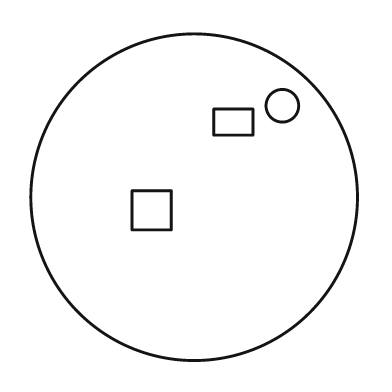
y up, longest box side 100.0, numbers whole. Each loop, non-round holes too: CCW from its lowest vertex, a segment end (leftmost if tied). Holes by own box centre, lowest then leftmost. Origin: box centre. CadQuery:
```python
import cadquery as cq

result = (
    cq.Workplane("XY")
    .moveTo(0.0, 0.0)
    .circle(50.0)
    .moveTo(-19.0, -10.0)
    .lineTo(-7.0, -10.0)
    .lineTo(-7.0, 2.0)
    .lineTo(-19.0, 2.0)
    .close()
    .moveTo(6.0, 19.0)
    .lineTo(18.0, 19.0)
    .lineTo(18.0, 27.0)
    .lineTo(6.0, 27.0)
    .close()
    .moveTo(27.0, 28.0)
    .circle(5.0)
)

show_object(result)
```